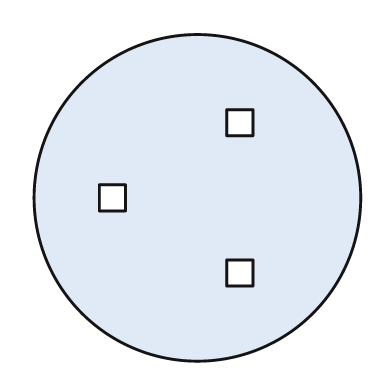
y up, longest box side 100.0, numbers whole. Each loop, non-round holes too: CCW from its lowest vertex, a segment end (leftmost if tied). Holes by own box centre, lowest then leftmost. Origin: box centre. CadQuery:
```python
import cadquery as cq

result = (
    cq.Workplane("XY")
    .moveTo(0.0, 0.0)
    .circle(50.0)
    .moveTo(9.0, -27.0)
    .lineTo(17.0, -27.0)
    .lineTo(17.0, -19.0)
    .lineTo(9.0, -19.0)
    .close()
    .moveTo(-30.0, -4.0)
    .lineTo(-22.0, -4.0)
    .lineTo(-22.0, 4.0)
    .lineTo(-30.0, 4.0)
    .close()
    .moveTo(9.0, 19.0)
    .lineTo(17.0, 19.0)
    .lineTo(17.0, 27.0)
    .lineTo(9.0, 27.0)
    .close()
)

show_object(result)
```